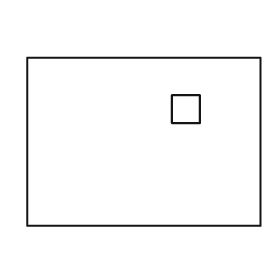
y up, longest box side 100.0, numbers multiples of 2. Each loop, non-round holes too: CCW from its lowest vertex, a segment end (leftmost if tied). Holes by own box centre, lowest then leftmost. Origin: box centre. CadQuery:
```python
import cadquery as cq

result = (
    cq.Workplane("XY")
    .moveTo(-50.0, -36.0)
    .lineTo(50.0, -36.0)
    .lineTo(50.0, 36.0)
    .lineTo(-50.0, 36.0)
    .close()
    .moveTo(12.0, 8.0)
    .lineTo(24.0, 8.0)
    .lineTo(24.0, 20.0)
    .lineTo(12.0, 20.0)
    .close()
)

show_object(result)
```